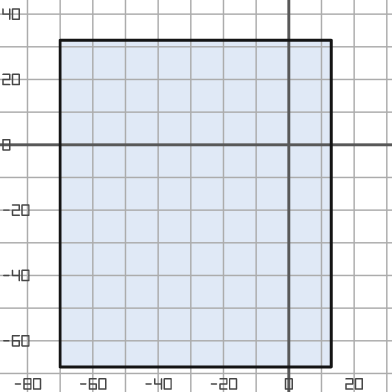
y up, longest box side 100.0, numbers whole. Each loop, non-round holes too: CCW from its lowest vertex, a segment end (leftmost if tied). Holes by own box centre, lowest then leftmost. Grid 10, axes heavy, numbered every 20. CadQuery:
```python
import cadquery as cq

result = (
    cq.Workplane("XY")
    .moveTo(-70.0, -68.0)
    .lineTo(13.0, -68.0)
    .lineTo(13.0, 32.0)
    .lineTo(-70.0, 32.0)
    .close()
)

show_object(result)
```